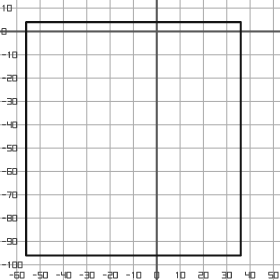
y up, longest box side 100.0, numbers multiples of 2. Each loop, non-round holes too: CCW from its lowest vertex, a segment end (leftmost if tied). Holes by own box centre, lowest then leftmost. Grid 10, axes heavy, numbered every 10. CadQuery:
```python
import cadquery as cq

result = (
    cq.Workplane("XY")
    .moveTo(-56.0, -96.0)
    .lineTo(36.0, -96.0)
    .lineTo(36.0, 4.0)
    .lineTo(-56.0, 4.0)
    .close()
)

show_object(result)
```